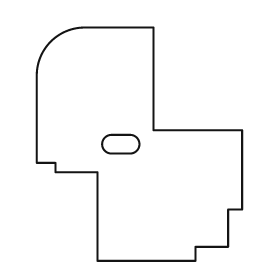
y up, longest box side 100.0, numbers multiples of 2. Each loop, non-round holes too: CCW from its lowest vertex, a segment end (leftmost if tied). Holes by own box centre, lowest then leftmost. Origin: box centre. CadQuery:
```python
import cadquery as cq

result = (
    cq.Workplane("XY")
    .moveTo(-18.0, -50.0)
    .lineTo(24.0, -50.0)
    .lineTo(24.0, -44.0)
    .lineTo(38.0, -44.0)
    .lineTo(38.0, -28.0)
    .lineTo(44.0, -28.0)
    .lineTo(44.0, 6.0)
    .lineTo(6.0, 6.0)
    .lineTo(6.0, 50.0)
    .lineTo(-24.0, 50.0)
    .threePointArc((-38.0, 44.0), (-44.0, 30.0))
    .lineTo(-44.0, -8.0)
    .lineTo(-36.0, -8.0)
    .lineTo(-36.0, -12.0)
    .lineTo(-18.0, -12.0)
    .close()
    .moveTo(-12.0, -4.0)
    .lineTo(-4.0, -4.0)
    .threePointArc((0.0, 0.0), (-4.0, 4.0))
    .lineTo(-12.0, 4.0)
    .threePointArc((-16.0, 0.0), (-12.0, -4.0))
    .close()
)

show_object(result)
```